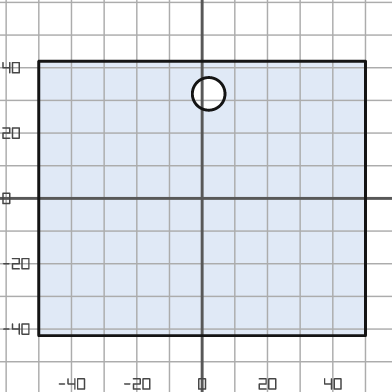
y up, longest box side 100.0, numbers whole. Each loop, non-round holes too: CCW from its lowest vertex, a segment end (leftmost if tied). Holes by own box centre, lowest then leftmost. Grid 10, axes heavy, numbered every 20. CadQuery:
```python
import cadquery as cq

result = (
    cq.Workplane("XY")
    .moveTo(-50.0, -42.0)
    .lineTo(50.0, -42.0)
    .lineTo(50.0, 42.0)
    .lineTo(-50.0, 42.0)
    .close()
    .moveTo(2.0, 32.0)
    .circle(5.0)
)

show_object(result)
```